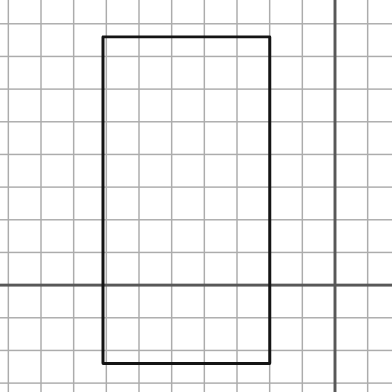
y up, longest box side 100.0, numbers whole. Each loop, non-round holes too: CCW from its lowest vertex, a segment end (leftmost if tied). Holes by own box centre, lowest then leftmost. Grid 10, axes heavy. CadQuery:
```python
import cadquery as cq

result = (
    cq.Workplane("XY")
    .moveTo(-71.0, -24.0)
    .lineTo(-20.0, -24.0)
    .lineTo(-20.0, 76.0)
    .lineTo(-71.0, 76.0)
    .close()
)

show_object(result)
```